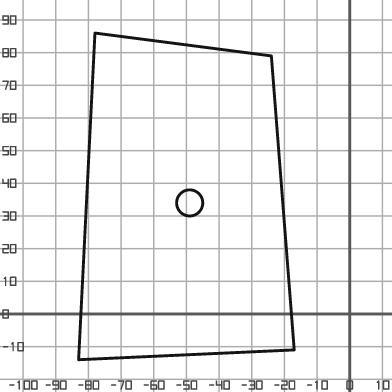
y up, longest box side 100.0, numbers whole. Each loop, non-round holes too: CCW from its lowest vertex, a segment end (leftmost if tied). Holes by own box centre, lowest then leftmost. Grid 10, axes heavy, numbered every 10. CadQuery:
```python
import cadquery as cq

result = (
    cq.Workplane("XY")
    .moveTo(-83.0, -14.0)
    .lineTo(-17.0, -11.0)
    .lineTo(-24.0, 79.0)
    .lineTo(-78.0, 86.0)
    .close()
    .moveTo(-49.0, 34.0)
    .circle(4.0)
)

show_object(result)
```